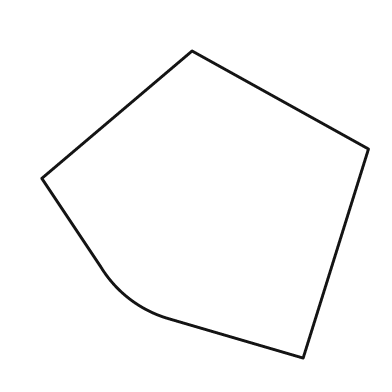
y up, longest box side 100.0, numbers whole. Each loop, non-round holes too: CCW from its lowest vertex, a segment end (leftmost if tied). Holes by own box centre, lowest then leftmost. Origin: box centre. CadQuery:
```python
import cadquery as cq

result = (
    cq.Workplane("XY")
    .moveTo(30.0, -47.0)
    .lineTo(50.0, 17.0)
    .lineTo(-4.0, 47.0)
    .lineTo(-50.0, 8.0)
    .lineTo(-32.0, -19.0)
    .threePointArc((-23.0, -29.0), (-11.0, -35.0))
    .close()
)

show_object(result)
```